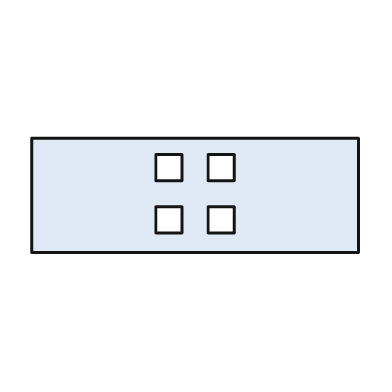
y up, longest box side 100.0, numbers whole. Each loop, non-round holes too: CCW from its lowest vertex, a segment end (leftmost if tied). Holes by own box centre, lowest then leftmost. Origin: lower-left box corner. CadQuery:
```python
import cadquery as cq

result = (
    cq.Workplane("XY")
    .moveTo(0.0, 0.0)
    .lineTo(100.0, 0.0)
    .lineTo(100.0, 35.0)
    .lineTo(0.0, 35.0)
    .close()
    .moveTo(38.0, 6.0)
    .lineTo(46.0, 6.0)
    .lineTo(46.0, 14.0)
    .lineTo(38.0, 14.0)
    .close()
    .moveTo(54.0, 6.0)
    .lineTo(62.0, 6.0)
    .lineTo(62.0, 14.0)
    .lineTo(54.0, 14.0)
    .close()
    .moveTo(38.0, 22.0)
    .lineTo(46.0, 22.0)
    .lineTo(46.0, 30.0)
    .lineTo(38.0, 30.0)
    .close()
    .moveTo(54.0, 22.0)
    .lineTo(62.0, 22.0)
    .lineTo(62.0, 30.0)
    .lineTo(54.0, 30.0)
    .close()
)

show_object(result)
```